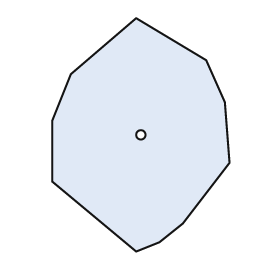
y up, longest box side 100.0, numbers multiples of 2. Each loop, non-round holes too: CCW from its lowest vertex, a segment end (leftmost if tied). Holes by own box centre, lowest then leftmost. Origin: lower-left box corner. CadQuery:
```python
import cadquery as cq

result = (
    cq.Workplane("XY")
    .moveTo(36.0, 0.0)
    .lineTo(46.0, 4.0)
    .lineTo(56.0, 12.0)
    .lineTo(76.0, 38.0)
    .lineTo(74.0, 64.0)
    .lineTo(66.0, 82.0)
    .lineTo(36.0, 100.0)
    .lineTo(8.0, 76.0)
    .lineTo(0.0, 56.0)
    .lineTo(0.0, 30.0)
    .close()
    .moveTo(38.0, 50.0)
    .circle(2.0)
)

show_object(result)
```